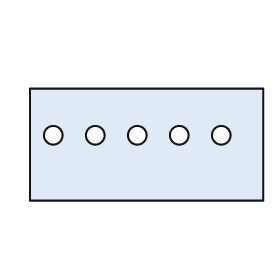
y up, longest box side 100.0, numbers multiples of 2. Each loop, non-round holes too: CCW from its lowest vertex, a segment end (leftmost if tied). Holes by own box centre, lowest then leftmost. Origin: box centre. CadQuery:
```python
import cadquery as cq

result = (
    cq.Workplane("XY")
    .moveTo(-50.0, -24.0)
    .lineTo(50.0, -24.0)
    .lineTo(50.0, 24.0)
    .lineTo(-50.0, 24.0)
    .close()
    .moveTo(-40.0, 4.0)
    .circle(4.0)
    .moveTo(-22.0, 4.0)
    .circle(4.0)
    .moveTo(-4.0, 4.0)
    .circle(4.0)
    .moveTo(14.0, 4.0)
    .circle(4.0)
    .moveTo(32.0, 4.0)
    .circle(4.0)
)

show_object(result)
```